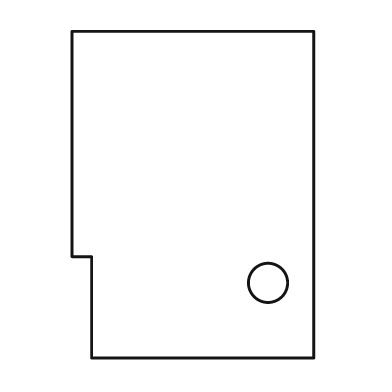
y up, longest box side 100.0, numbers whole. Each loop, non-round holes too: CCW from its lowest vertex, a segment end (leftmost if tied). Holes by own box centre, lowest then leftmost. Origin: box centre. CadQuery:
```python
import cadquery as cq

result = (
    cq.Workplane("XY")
    .moveTo(-31.0, -50.0)
    .lineTo(37.0, -50.0)
    .lineTo(37.0, 50.0)
    .lineTo(-37.0, 50.0)
    .lineTo(-37.0, -19.0)
    .lineTo(-31.0, -19.0)
    .close()
    .moveTo(23.0, -27.0)
    .circle(6.0)
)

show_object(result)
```